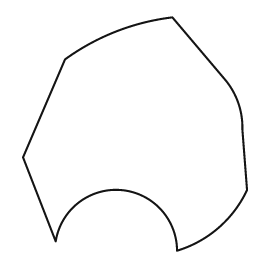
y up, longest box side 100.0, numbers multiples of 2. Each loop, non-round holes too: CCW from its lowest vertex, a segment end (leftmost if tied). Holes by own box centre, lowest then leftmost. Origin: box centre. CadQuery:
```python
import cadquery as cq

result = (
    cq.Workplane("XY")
    .moveTo(18.0, -50.0)
    .threePointArc((36.0, -40.0), (48.0, -24.0))
    .lineTo(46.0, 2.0)
    .threePointArc((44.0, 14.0), (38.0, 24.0))
    .lineTo(16.0, 50.0)
    .threePointArc((-8.0, 44.0), (-30.0, 32.0))
    .lineTo(-48.0, -10.0)
    .lineTo(-34.0, -46.0)
    .threePointArc((-6.0, -24.0), (18.0, -50.0))
    .close()
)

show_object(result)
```